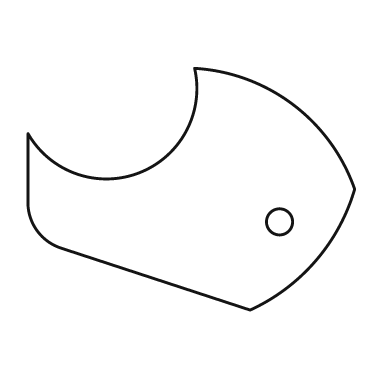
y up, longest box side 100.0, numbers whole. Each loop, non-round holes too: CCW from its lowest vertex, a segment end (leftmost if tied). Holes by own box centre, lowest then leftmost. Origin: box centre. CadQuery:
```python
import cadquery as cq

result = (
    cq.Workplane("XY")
    .moveTo(18.0, -37.0)
    .threePointArc((38.0, -22.0), (50.0, 0.0))
    .threePointArc((31.0, 26.0), (1.0, 37.0))
    .threePointArc((-16.0, 5.0), (-50.0, 17.0))
    .lineTo(-50.0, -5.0)
    .threePointArc((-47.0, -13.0), (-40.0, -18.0))
    .close()
    .moveTo(27.0, -10.0)
    .circle(4.0)
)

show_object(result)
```